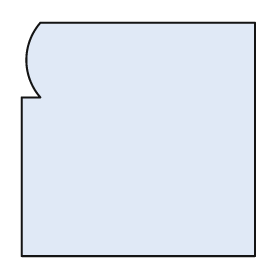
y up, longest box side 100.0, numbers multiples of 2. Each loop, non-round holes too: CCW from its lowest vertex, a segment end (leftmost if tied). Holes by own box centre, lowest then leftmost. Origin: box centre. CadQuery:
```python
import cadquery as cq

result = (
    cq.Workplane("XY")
    .moveTo(-50.0, -50.0)
    .lineTo(50.0, -50.0)
    .lineTo(50.0, 50.0)
    .lineTo(-42.0, 50.0)
    .threePointArc((-48.0, 34.0), (-42.0, 18.0))
    .lineTo(-50.0, 18.0)
    .close()
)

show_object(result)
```